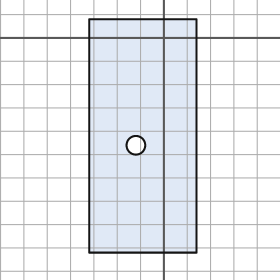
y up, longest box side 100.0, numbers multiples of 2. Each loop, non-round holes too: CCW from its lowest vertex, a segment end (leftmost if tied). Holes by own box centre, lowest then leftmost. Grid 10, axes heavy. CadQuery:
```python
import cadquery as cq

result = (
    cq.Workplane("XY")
    .moveTo(-32.0, -92.0)
    .lineTo(14.0, -92.0)
    .lineTo(14.0, 8.0)
    .lineTo(-32.0, 8.0)
    .close()
    .moveTo(-12.0, -46.0)
    .circle(4.0)
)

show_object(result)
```